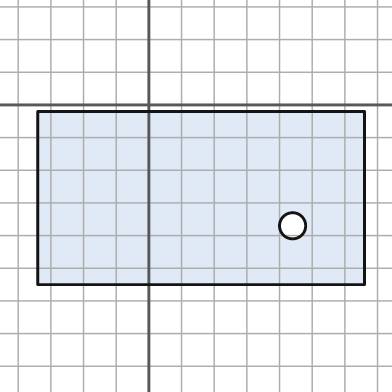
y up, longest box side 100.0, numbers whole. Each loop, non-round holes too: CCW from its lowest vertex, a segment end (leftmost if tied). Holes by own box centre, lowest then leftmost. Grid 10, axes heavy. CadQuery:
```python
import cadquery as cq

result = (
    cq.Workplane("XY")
    .moveTo(-34.0, -55.0)
    .lineTo(66.0, -55.0)
    .lineTo(66.0, -2.0)
    .lineTo(-34.0, -2.0)
    .close()
    .moveTo(44.0, -37.0)
    .circle(4.0)
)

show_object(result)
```